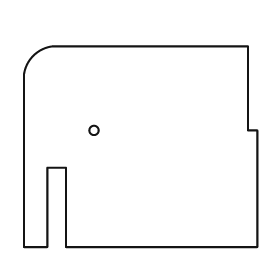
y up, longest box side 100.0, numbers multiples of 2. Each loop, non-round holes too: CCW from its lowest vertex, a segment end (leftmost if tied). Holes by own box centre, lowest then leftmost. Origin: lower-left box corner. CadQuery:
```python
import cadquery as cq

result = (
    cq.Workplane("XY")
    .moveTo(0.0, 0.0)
    .lineTo(10.0, 0.0)
    .lineTo(10.0, 34.0)
    .lineTo(18.0, 34.0)
    .lineTo(18.0, 0.0)
    .lineTo(100.0, 0.0)
    .lineTo(100.0, 50.0)
    .lineTo(96.0, 50.0)
    .lineTo(96.0, 86.0)
    .lineTo(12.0, 86.0)
    .threePointArc((4.0, 82.0), (0.0, 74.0))
    .close()
    .moveTo(30.0, 50.0)
    .circle(2.0)
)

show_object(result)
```